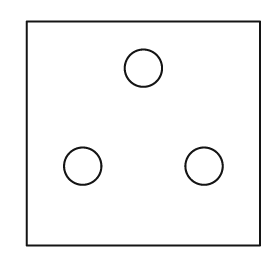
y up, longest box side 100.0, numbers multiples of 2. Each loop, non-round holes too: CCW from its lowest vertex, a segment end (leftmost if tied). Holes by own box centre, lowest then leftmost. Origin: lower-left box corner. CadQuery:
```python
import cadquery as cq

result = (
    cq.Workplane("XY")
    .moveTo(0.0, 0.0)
    .lineTo(100.0, 0.0)
    .lineTo(100.0, 96.0)
    .lineTo(0.0, 96.0)
    .close()
    .moveTo(24.0, 34.0)
    .circle(8.0)
    .moveTo(76.0, 34.0)
    .circle(8.0)
    .moveTo(50.0, 76.0)
    .circle(8.0)
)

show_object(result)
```